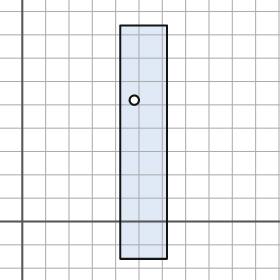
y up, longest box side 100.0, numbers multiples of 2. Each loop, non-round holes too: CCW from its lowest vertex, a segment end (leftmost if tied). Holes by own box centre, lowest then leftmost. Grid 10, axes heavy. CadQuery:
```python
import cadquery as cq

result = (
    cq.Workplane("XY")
    .moveTo(42.0, -16.0)
    .lineTo(62.0, -16.0)
    .lineTo(62.0, 84.0)
    .lineTo(42.0, 84.0)
    .close()
    .moveTo(48.0, 52.0)
    .circle(2.0)
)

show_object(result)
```